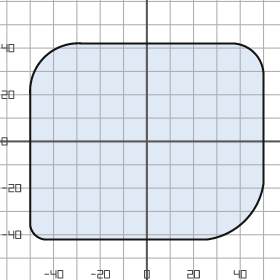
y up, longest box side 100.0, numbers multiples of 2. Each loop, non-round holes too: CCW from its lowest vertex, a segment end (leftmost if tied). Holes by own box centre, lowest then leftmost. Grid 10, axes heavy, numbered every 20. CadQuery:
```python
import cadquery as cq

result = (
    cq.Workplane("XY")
    .moveTo(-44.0, -42.0)
    .lineTo(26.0, -42.0)
    .threePointArc((42.0, -34.0), (50.0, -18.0))
    .lineTo(50.0, 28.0)
    .threePointArc((46.0, 38.0), (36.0, 42.0))
    .lineTo(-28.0, 42.0)
    .threePointArc((-44.0, 36.0), (-50.0, 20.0))
    .lineTo(-50.0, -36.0)
    .threePointArc((-48.0, -40.0), (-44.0, -42.0))
    .close()
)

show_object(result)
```